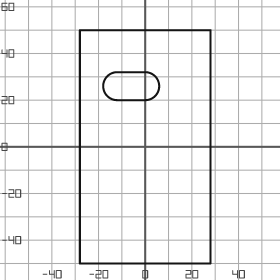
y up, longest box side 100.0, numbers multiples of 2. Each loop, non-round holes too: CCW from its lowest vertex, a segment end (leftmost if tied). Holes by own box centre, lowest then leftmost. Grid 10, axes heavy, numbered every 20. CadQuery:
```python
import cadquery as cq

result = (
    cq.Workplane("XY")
    .moveTo(-28.0, -50.0)
    .lineTo(28.0, -50.0)
    .lineTo(28.0, 50.0)
    .lineTo(-28.0, 50.0)
    .close()
    .moveTo(-12.0, 20.0)
    .lineTo(0.0, 20.0)
    .threePointArc((6.0, 26.0), (0.0, 32.0))
    .lineTo(-12.0, 32.0)
    .threePointArc((-18.0, 26.0), (-12.0, 20.0))
    .close()
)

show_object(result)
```